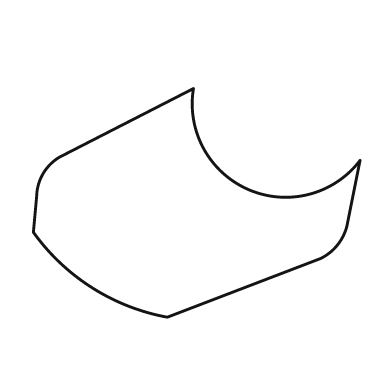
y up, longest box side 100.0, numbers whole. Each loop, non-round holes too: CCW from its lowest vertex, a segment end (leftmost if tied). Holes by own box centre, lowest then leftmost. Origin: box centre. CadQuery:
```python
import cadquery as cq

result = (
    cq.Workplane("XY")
    .moveTo(-9.0, -35.0)
    .lineTo(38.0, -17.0)
    .threePointArc((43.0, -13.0), (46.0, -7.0))
    .lineTo(50.0, 13.0)
    .threePointArc((16.0, 4.0), (-1.0, 35.0))
    .lineTo(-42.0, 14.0)
    .threePointArc((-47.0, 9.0), (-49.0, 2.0))
    .lineTo(-50.0, -9.0)
    .threePointArc((-32.0, -26.0), (-9.0, -35.0))
    .close()
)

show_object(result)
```